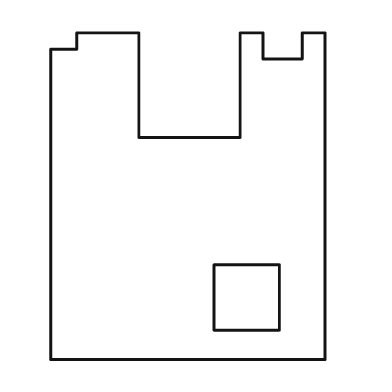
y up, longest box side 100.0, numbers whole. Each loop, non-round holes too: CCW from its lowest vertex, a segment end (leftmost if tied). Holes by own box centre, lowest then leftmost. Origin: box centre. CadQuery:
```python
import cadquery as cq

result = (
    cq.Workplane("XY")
    .moveTo(-42.0, -50.0)
    .lineTo(42.0, -50.0)
    .lineTo(42.0, 50.0)
    .lineTo(35.0, 50.0)
    .lineTo(35.0, 42.0)
    .lineTo(23.0, 42.0)
    .lineTo(23.0, 50.0)
    .lineTo(16.0, 50.0)
    .lineTo(16.0, 18.0)
    .lineTo(-15.0, 18.0)
    .lineTo(-15.0, 50.0)
    .lineTo(-34.0, 50.0)
    .lineTo(-34.0, 45.0)
    .lineTo(-42.0, 45.0)
    .close()
    .moveTo(8.0, -41.0)
    .lineTo(28.0, -41.0)
    .lineTo(28.0, -21.0)
    .lineTo(8.0, -21.0)
    .close()
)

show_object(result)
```